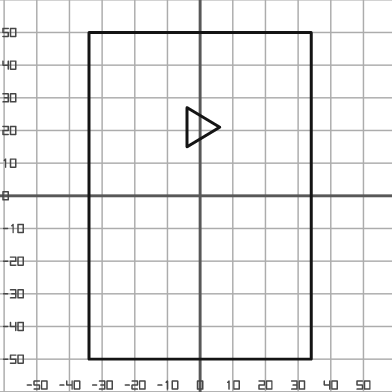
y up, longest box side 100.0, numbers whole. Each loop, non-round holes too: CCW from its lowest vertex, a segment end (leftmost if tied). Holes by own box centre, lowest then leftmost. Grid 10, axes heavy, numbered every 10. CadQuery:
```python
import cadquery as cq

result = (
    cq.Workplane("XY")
    .moveTo(-34.0, -50.0)
    .lineTo(34.0, -50.0)
    .lineTo(34.0, 50.0)
    .lineTo(-34.0, 50.0)
    .close()
    .moveTo(-4.0, 15.0)
    .lineTo(6.0, 21.0)
    .lineTo(-4.0, 27.0)
    .close()
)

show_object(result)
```